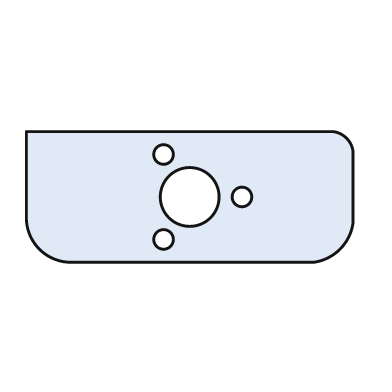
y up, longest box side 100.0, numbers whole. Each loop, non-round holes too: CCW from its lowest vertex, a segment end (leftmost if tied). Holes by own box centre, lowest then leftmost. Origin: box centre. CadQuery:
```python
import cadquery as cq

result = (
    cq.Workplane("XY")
    .moveTo(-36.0, -20.0)
    .lineTo(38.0, -20.0)
    .threePointArc((46.0, -16.0), (50.0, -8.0))
    .lineTo(50.0, 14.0)
    .threePointArc((48.0, 18.0), (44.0, 20.0))
    .lineTo(-50.0, 20.0)
    .lineTo(-50.0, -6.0)
    .threePointArc((-46.0, -16.0), (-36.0, -20.0))
    .close()
    .moveTo(-8.0, -13.0)
    .circle(3.0)
    .moveTo(0.0, 0.0)
    .circle(9.0)
    .moveTo(16.0, 0.0)
    .circle(3.0)
    .moveTo(-8.0, 13.0)
    .circle(3.0)
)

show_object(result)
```